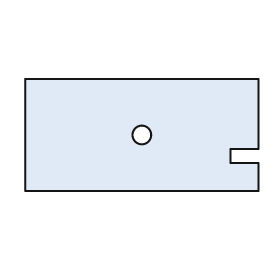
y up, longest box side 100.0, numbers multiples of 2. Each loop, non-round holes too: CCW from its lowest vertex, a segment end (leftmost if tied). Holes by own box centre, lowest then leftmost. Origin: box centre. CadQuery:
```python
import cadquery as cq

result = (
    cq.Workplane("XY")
    .moveTo(-50.0, -24.0)
    .lineTo(50.0, -24.0)
    .lineTo(50.0, -12.0)
    .lineTo(38.0, -12.0)
    .lineTo(38.0, -6.0)
    .lineTo(50.0, -6.0)
    .lineTo(50.0, 24.0)
    .lineTo(-50.0, 24.0)
    .close()
    .moveTo(0.0, 0.0)
    .circle(4.0)
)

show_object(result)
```